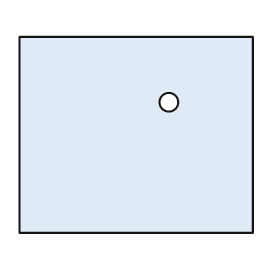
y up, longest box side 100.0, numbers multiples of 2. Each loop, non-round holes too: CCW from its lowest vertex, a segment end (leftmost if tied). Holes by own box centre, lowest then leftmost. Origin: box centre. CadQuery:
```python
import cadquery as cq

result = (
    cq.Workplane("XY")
    .moveTo(-50.0, -42.0)
    .lineTo(50.0, -42.0)
    .lineTo(50.0, 42.0)
    .lineTo(-50.0, 42.0)
    .close()
    .moveTo(14.0, 14.0)
    .circle(4.0)
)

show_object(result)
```